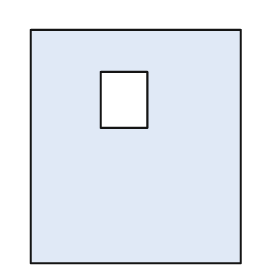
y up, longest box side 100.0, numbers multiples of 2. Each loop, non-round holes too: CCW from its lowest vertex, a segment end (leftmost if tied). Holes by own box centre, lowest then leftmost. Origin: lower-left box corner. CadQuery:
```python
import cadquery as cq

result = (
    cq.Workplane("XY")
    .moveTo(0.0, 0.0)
    .lineTo(90.0, 0.0)
    .lineTo(90.0, 100.0)
    .lineTo(0.0, 100.0)
    .close()
    .moveTo(30.0, 58.0)
    .lineTo(50.0, 58.0)
    .lineTo(50.0, 82.0)
    .lineTo(30.0, 82.0)
    .close()
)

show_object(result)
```